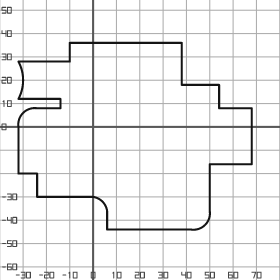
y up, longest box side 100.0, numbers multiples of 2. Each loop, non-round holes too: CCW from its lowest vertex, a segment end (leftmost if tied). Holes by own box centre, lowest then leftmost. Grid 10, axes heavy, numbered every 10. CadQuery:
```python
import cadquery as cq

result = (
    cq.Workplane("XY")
    .moveTo(6.0, -44.0)
    .lineTo(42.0, -44.0)
    .threePointArc((48.0, -42.0), (50.0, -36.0))
    .lineTo(50.0, -16.0)
    .lineTo(68.0, -16.0)
    .lineTo(68.0, 8.0)
    .lineTo(54.0, 8.0)
    .lineTo(54.0, 18.0)
    .lineTo(38.0, 18.0)
    .lineTo(38.0, 36.0)
    .lineTo(-10.0, 36.0)
    .lineTo(-10.0, 28.0)
    .lineTo(-32.0, 28.0)
    .threePointArc((-30.0, 20.0), (-32.0, 12.0))
    .lineTo(-14.0, 12.0)
    .lineTo(-14.0, 8.0)
    .lineTo(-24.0, 8.0)
    .threePointArc((-30.0, 6.0), (-32.0, 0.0))
    .lineTo(-32.0, -20.0)
    .lineTo(-24.0, -20.0)
    .lineTo(-24.0, -30.0)
    .lineTo(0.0, -30.0)
    .threePointArc((4.0, -32.0), (6.0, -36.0))
    .close()
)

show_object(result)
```